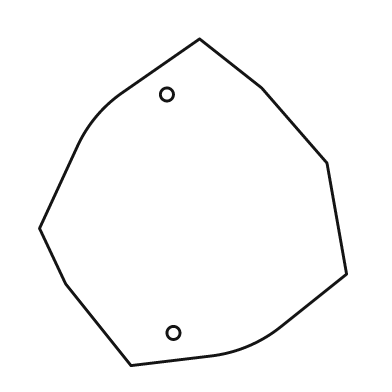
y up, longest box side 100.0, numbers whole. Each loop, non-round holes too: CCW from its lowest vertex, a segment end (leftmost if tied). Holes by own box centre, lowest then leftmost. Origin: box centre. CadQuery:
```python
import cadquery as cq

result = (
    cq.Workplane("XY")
    .moveTo(-19.0, -50.0)
    .lineTo(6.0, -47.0)
    .threePointArc((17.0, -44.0), (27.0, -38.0))
    .lineTo(47.0, -22.0)
    .lineTo(41.0, 12.0)
    .lineTo(21.0, 35.0)
    .lineTo(2.0, 50.0)
    .lineTo(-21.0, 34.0)
    .threePointArc((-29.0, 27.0), (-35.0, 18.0))
    .lineTo(-47.0, -8.0)
    .lineTo(-39.0, -25.0)
    .close()
    .moveTo(-6.0, -40.0)
    .circle(2.0)
    .moveTo(-8.0, 33.0)
    .circle(2.0)
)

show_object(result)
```